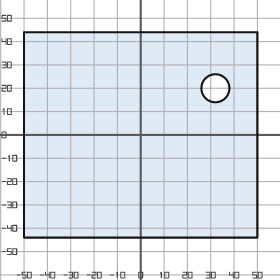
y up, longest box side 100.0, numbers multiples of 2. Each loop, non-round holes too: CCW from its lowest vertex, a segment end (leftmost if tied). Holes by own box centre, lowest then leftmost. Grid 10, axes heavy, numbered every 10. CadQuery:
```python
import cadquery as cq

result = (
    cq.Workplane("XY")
    .moveTo(-50.0, -44.0)
    .lineTo(50.0, -44.0)
    .lineTo(50.0, 44.0)
    .lineTo(-50.0, 44.0)
    .close()
    .moveTo(32.0, 20.0)
    .circle(6.0)
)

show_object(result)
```